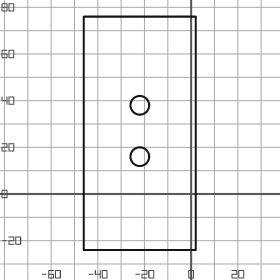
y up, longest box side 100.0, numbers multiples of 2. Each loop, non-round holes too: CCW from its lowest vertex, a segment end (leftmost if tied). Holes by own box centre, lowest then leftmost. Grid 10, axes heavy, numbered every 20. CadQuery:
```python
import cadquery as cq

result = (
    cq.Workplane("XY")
    .moveTo(-46.0, -24.0)
    .lineTo(2.0, -24.0)
    .lineTo(2.0, 76.0)
    .lineTo(-46.0, 76.0)
    .close()
    .moveTo(-22.0, 16.0)
    .circle(4.0)
    .moveTo(-22.0, 38.0)
    .circle(4.0)
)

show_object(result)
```